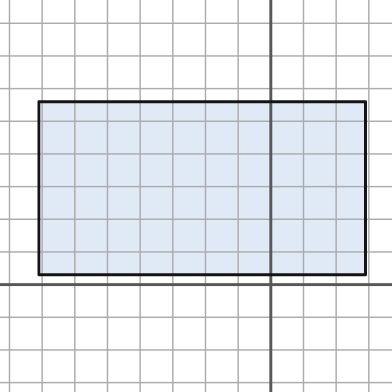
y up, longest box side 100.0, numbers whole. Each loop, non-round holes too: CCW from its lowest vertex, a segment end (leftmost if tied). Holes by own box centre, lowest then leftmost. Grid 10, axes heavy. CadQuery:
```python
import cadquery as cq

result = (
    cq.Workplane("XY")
    .moveTo(-71.0, 3.0)
    .lineTo(29.0, 3.0)
    .lineTo(29.0, 56.0)
    .lineTo(-71.0, 56.0)
    .close()
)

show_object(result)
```